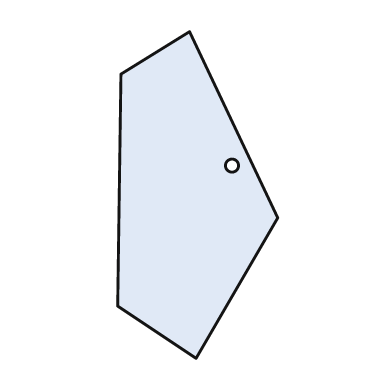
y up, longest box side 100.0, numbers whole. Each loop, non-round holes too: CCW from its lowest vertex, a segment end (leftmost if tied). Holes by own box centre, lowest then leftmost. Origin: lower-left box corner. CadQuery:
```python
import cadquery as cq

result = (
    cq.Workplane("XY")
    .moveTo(24.0, 0.0)
    .lineTo(49.0, 43.0)
    .lineTo(22.0, 100.0)
    .lineTo(1.0, 87.0)
    .lineTo(0.0, 16.0)
    .close()
    .moveTo(35.0, 59.0)
    .circle(2.0)
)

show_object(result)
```